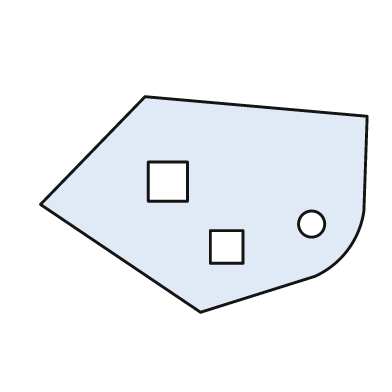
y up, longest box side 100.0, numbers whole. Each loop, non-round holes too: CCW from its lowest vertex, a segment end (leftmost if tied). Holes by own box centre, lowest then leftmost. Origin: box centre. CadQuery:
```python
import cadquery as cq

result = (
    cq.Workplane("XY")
    .moveTo(-1.0, -33.0)
    .lineTo(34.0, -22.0)
    .threePointArc((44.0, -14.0), (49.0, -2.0))
    .lineTo(50.0, 27.0)
    .lineTo(-18.0, 33.0)
    .lineTo(-50.0, 0.0)
    .close()
    .moveTo(2.0, -18.0)
    .lineTo(12.0, -18.0)
    .lineTo(12.0, -8.0)
    .lineTo(2.0, -8.0)
    .close()
    .moveTo(33.0, -6.0)
    .circle(4.0)
    .moveTo(-17.0, 1.0)
    .lineTo(-5.0, 1.0)
    .lineTo(-5.0, 13.0)
    .lineTo(-17.0, 13.0)
    .close()
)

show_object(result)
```